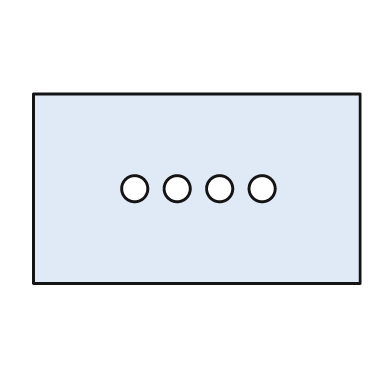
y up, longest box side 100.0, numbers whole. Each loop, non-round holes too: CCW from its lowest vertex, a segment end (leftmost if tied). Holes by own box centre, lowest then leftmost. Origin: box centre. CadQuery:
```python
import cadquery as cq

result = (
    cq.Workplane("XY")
    .moveTo(-50.0, -29.0)
    .lineTo(50.0, -29.0)
    .lineTo(50.0, 29.0)
    .lineTo(-50.0, 29.0)
    .close()
    .moveTo(-19.0, 0.0)
    .circle(4.0)
    .moveTo(-6.0, 0.0)
    .circle(4.0)
    .moveTo(7.0, 0.0)
    .circle(4.0)
    .moveTo(20.0, 0.0)
    .circle(4.0)
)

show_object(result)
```